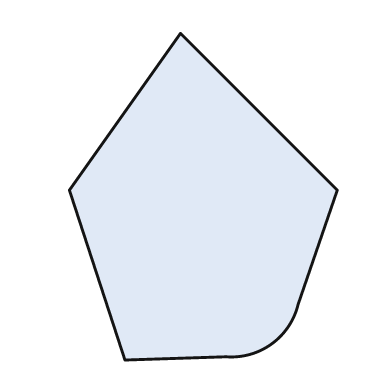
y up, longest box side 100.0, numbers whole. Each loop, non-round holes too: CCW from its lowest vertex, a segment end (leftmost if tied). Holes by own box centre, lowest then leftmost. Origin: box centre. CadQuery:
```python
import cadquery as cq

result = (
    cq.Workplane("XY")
    .moveTo(-24.0, -50.0)
    .lineTo(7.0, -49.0)
    .threePointArc((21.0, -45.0), (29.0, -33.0))
    .lineTo(41.0, 2.0)
    .lineTo(-7.0, 50.0)
    .lineTo(-41.0, 2.0)
    .close()
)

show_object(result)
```